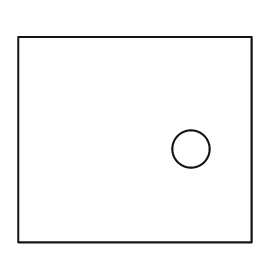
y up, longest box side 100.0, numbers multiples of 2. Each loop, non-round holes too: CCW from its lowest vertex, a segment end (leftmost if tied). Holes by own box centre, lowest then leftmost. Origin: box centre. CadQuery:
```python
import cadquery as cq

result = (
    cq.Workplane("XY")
    .moveTo(-50.0, -44.0)
    .lineTo(50.0, -44.0)
    .lineTo(50.0, 44.0)
    .lineTo(-50.0, 44.0)
    .close()
    .moveTo(24.0, -4.0)
    .circle(8.0)
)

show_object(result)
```